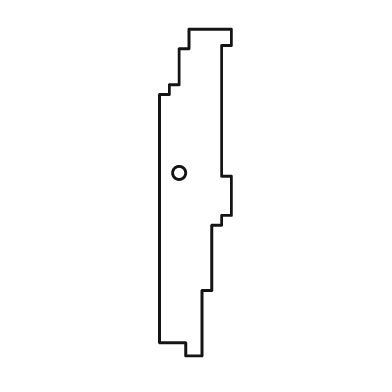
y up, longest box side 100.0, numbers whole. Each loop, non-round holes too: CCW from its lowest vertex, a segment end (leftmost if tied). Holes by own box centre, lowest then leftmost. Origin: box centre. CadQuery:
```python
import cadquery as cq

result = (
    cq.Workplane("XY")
    .moveTo(-3.0, -50.0)
    .lineTo(2.0, -50.0)
    .lineTo(2.0, -30.0)
    .lineTo(5.0, -30.0)
    .lineTo(5.0, -10.0)
    .lineTo(8.0, -10.0)
    .lineTo(8.0, -7.0)
    .lineTo(11.0, -7.0)
    .lineTo(11.0, 5.0)
    .lineTo(8.0, 5.0)
    .lineTo(8.0, 45.0)
    .lineTo(11.0, 45.0)
    .lineTo(11.0, 50.0)
    .lineTo(-2.0, 50.0)
    .lineTo(-2.0, 44.0)
    .lineTo(-5.0, 44.0)
    .lineTo(-5.0, 33.0)
    .lineTo(-8.0, 33.0)
    .lineTo(-8.0, 30.0)
    .lineTo(-11.0, 30.0)
    .lineTo(-11.0, -46.0)
    .lineTo(-3.0, -46.0)
    .close()
    .moveTo(-5.0, 6.0)
    .circle(2.0)
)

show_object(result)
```